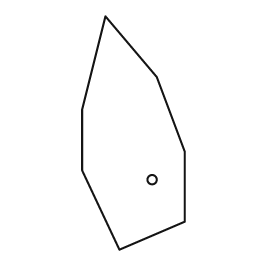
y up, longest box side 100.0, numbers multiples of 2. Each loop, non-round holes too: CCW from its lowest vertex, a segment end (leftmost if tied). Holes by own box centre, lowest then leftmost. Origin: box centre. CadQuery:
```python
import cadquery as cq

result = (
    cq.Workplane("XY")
    .moveTo(-6.0, -50.0)
    .lineTo(22.0, -38.0)
    .lineTo(22.0, -8.0)
    .lineTo(10.0, 24.0)
    .lineTo(-12.0, 50.0)
    .lineTo(-22.0, 10.0)
    .lineTo(-22.0, -16.0)
    .close()
    .moveTo(8.0, -20.0)
    .circle(2.0)
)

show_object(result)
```